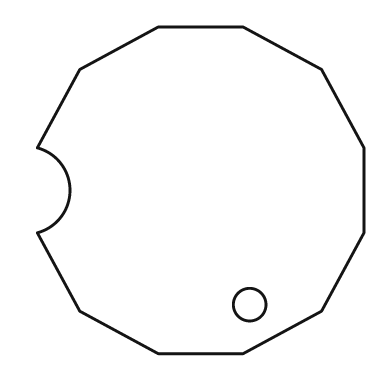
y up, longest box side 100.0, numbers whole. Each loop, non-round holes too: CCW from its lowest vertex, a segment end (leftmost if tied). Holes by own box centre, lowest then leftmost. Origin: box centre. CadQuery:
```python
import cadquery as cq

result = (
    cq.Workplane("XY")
    .moveTo(-13.0, -50.0)
    .lineTo(13.0, -50.0)
    .lineTo(37.0, -37.0)
    .lineTo(50.0, -13.0)
    .lineTo(50.0, 13.0)
    .lineTo(37.0, 37.0)
    .lineTo(13.0, 50.0)
    .lineTo(-13.0, 50.0)
    .lineTo(-37.0, 37.0)
    .lineTo(-50.0, 13.0)
    .threePointArc((-40.0, 0.0), (-50.0, -13.0))
    .lineTo(-37.0, -37.0)
    .close()
    .moveTo(15.0, -35.0)
    .circle(5.0)
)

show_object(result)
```